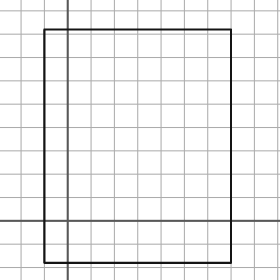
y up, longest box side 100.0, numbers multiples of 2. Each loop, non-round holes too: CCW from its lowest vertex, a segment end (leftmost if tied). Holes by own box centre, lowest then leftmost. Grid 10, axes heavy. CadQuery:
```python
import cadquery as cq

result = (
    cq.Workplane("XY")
    .moveTo(-10.0, -18.0)
    .lineTo(70.0, -18.0)
    .lineTo(70.0, 82.0)
    .lineTo(-10.0, 82.0)
    .close()
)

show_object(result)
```